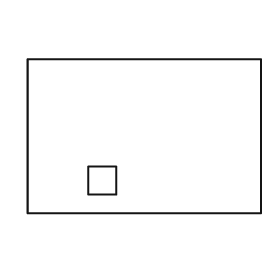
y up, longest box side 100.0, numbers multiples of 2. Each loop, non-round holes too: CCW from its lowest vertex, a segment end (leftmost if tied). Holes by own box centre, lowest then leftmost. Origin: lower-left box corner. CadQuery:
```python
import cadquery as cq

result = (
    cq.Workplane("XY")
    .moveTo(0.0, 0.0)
    .lineTo(100.0, 0.0)
    .lineTo(100.0, 66.0)
    .lineTo(0.0, 66.0)
    .close()
    .moveTo(26.0, 8.0)
    .lineTo(38.0, 8.0)
    .lineTo(38.0, 20.0)
    .lineTo(26.0, 20.0)
    .close()
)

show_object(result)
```